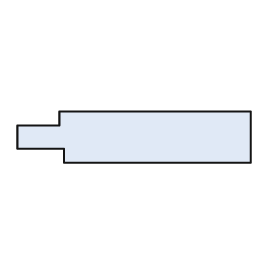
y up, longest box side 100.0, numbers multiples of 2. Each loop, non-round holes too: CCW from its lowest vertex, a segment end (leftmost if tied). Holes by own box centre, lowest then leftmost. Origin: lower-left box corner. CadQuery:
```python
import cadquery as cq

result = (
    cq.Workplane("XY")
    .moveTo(20.0, 0.0)
    .lineTo(100.0, 0.0)
    .lineTo(100.0, 22.0)
    .lineTo(18.0, 22.0)
    .lineTo(18.0, 16.0)
    .lineTo(0.0, 16.0)
    .lineTo(0.0, 6.0)
    .lineTo(20.0, 6.0)
    .close()
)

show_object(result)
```